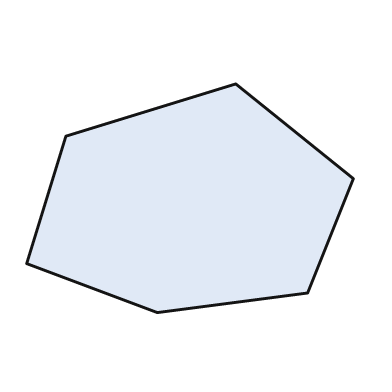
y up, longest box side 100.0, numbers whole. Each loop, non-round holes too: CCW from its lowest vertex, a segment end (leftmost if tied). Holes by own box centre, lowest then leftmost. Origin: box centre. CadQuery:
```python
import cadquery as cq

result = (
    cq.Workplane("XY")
    .moveTo(-10.0, -35.0)
    .lineTo(36.0, -29.0)
    .lineTo(50.0, 6.0)
    .lineTo(14.0, 35.0)
    .lineTo(-38.0, 19.0)
    .lineTo(-50.0, -20.0)
    .close()
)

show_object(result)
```